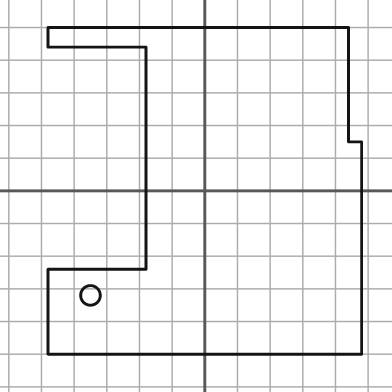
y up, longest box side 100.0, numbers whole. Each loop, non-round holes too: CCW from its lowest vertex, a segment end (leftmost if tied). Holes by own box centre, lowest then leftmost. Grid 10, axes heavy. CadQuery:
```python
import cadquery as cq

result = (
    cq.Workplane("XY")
    .moveTo(-48.0, -50.0)
    .lineTo(48.0, -50.0)
    .lineTo(48.0, 15.0)
    .lineTo(44.0, 15.0)
    .lineTo(44.0, 50.0)
    .lineTo(-48.0, 50.0)
    .lineTo(-48.0, 44.0)
    .lineTo(-18.0, 44.0)
    .lineTo(-18.0, -24.0)
    .lineTo(-48.0, -24.0)
    .close()
    .moveTo(-35.0, -32.0)
    .circle(3.0)
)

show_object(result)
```